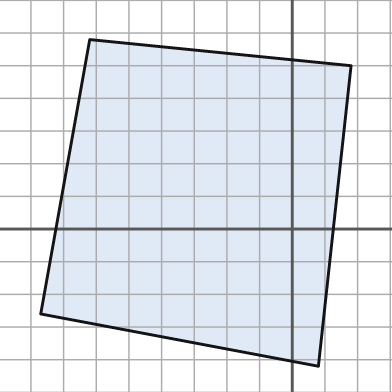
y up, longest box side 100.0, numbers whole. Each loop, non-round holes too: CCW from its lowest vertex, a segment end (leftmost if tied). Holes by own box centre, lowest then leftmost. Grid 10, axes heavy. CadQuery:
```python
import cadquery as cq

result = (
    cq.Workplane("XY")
    .moveTo(8.0, -42.0)
    .lineTo(18.0, 50.0)
    .lineTo(-62.0, 58.0)
    .lineTo(-77.0, -26.0)
    .close()
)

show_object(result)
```